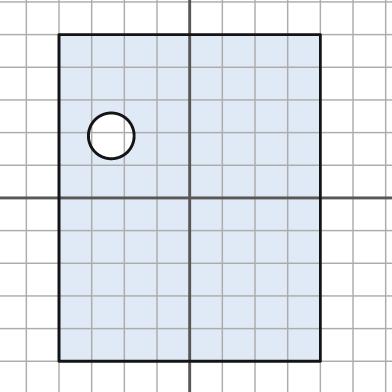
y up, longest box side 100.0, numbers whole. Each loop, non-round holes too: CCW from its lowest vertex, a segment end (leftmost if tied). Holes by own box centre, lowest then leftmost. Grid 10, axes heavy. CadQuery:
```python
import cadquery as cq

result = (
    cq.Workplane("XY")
    .moveTo(-40.0, -50.0)
    .lineTo(40.0, -50.0)
    .lineTo(40.0, 50.0)
    .lineTo(-40.0, 50.0)
    .close()
    .moveTo(-24.0, 19.0)
    .circle(7.0)
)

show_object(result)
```